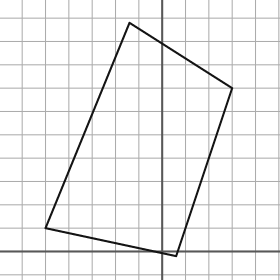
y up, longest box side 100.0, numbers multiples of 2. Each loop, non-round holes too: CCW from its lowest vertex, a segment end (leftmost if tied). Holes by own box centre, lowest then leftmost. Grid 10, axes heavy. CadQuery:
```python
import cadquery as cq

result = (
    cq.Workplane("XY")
    .moveTo(6.0, -2.0)
    .lineTo(30.0, 70.0)
    .lineTo(-14.0, 98.0)
    .lineTo(-50.0, 10.0)
    .close()
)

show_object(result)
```